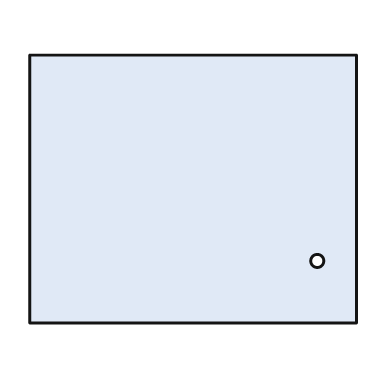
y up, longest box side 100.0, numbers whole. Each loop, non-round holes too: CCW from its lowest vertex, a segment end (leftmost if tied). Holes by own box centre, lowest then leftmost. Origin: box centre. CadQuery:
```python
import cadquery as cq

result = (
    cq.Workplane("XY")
    .moveTo(-50.0, -41.0)
    .lineTo(50.0, -41.0)
    .lineTo(50.0, 41.0)
    .lineTo(-50.0, 41.0)
    .close()
    .moveTo(38.0, -22.0)
    .circle(2.0)
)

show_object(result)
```